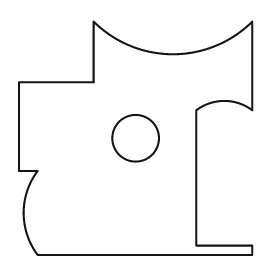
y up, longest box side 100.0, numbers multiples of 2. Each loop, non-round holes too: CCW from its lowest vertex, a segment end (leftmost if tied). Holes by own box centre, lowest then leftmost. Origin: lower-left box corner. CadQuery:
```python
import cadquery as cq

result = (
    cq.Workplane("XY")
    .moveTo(8.0, 0.0)
    .lineTo(100.0, 0.0)
    .lineTo(100.0, 4.0)
    .lineTo(76.0, 4.0)
    .lineTo(76.0, 62.0)
    .threePointArc((88.0, 66.0), (100.0, 62.0))
    .lineTo(100.0, 100.0)
    .threePointArc((66.0, 86.0), (32.0, 100.0))
    .lineTo(32.0, 74.0)
    .lineTo(0.0, 74.0)
    .lineTo(0.0, 36.0)
    .lineTo(8.0, 36.0)
    .threePointArc((2.0, 18.0), (8.0, 0.0))
    .close()
    .moveTo(50.0, 50.0)
    .circle(10.0)
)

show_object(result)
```